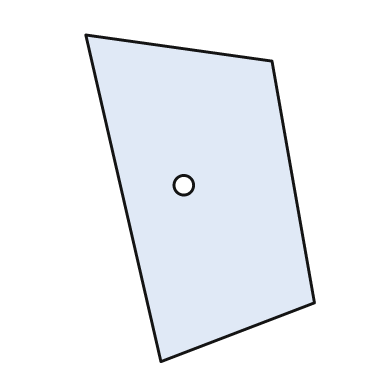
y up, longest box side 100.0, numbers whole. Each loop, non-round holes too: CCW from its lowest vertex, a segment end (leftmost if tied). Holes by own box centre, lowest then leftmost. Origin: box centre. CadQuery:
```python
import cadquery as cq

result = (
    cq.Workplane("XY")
    .moveTo(-12.0, -50.0)
    .lineTo(35.0, -32.0)
    .lineTo(22.0, 42.0)
    .lineTo(-35.0, 50.0)
    .close()
    .moveTo(-5.0, 4.0)
    .circle(3.0)
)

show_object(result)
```